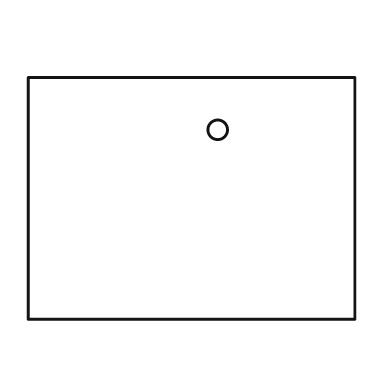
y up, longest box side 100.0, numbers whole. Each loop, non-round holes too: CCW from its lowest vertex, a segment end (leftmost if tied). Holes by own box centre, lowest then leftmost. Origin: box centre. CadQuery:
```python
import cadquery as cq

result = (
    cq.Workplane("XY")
    .moveTo(-50.0, -37.0)
    .lineTo(50.0, -37.0)
    .lineTo(50.0, 37.0)
    .lineTo(-50.0, 37.0)
    .close()
    .moveTo(8.0, 21.0)
    .circle(3.0)
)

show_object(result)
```